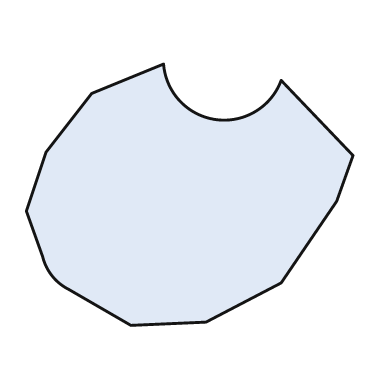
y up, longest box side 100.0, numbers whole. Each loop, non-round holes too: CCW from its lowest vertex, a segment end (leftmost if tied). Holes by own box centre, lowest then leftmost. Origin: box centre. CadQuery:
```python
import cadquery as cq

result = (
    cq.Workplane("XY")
    .moveTo(-18.0, -40.0)
    .lineTo(5.0, -39.0)
    .lineTo(28.0, -27.0)
    .lineTo(45.0, -2.0)
    .lineTo(50.0, 12.0)
    .lineTo(28.0, 35.0)
    .threePointArc((8.0, 23.0), (-8.0, 40.0))
    .lineTo(-30.0, 31.0)
    .lineTo(-44.0, 13.0)
    .lineTo(-50.0, -5.0)
    .lineTo(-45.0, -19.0)
    .threePointArc((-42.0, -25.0), (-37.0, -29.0))
    .close()
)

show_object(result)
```